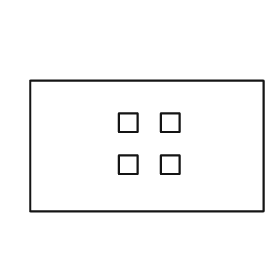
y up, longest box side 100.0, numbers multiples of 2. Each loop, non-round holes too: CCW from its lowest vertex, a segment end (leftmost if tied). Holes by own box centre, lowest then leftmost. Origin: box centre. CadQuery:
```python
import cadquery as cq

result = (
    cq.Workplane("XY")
    .moveTo(-50.0, -28.0)
    .lineTo(50.0, -28.0)
    .lineTo(50.0, 28.0)
    .lineTo(-50.0, 28.0)
    .close()
    .moveTo(-12.0, -12.0)
    .lineTo(-4.0, -12.0)
    .lineTo(-4.0, -4.0)
    .lineTo(-12.0, -4.0)
    .close()
    .moveTo(6.0, -12.0)
    .lineTo(14.0, -12.0)
    .lineTo(14.0, -4.0)
    .lineTo(6.0, -4.0)
    .close()
    .moveTo(-12.0, 6.0)
    .lineTo(-4.0, 6.0)
    .lineTo(-4.0, 14.0)
    .lineTo(-12.0, 14.0)
    .close()
    .moveTo(6.0, 6.0)
    .lineTo(14.0, 6.0)
    .lineTo(14.0, 14.0)
    .lineTo(6.0, 14.0)
    .close()
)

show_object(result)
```